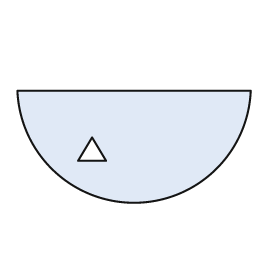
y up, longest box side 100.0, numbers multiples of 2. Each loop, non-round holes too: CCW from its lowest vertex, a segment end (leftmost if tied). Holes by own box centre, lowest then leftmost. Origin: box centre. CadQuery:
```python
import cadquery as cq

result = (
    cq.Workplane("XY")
    .moveTo(-50.0, 24.0)
    .threePointArc((0.0, -24.0), (50.0, 24.0))
    .close()
    .moveTo(-24.0, -6.0)
    .lineTo(-12.0, -6.0)
    .lineTo(-18.0, 4.0)
    .close()
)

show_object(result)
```